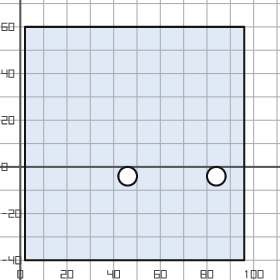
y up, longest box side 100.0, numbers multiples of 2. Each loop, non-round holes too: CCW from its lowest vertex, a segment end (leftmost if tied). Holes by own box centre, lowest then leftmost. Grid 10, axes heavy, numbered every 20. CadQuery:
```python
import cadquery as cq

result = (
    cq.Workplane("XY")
    .moveTo(2.0, -40.0)
    .lineTo(96.0, -40.0)
    .lineTo(96.0, 60.0)
    .lineTo(2.0, 60.0)
    .close()
    .moveTo(46.0, -4.0)
    .circle(4.0)
    .moveTo(84.0, -4.0)
    .circle(4.0)
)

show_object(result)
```